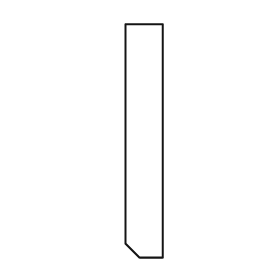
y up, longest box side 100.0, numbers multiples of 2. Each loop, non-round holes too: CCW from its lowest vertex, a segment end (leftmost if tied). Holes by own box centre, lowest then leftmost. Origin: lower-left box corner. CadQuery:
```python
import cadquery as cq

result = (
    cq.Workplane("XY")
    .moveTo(6.0, 0.0)
    .lineTo(16.0, 0.0)
    .lineTo(16.0, 100.0)
    .lineTo(0.0, 100.0)
    .lineTo(0.0, 6.0)
    .close()
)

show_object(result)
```